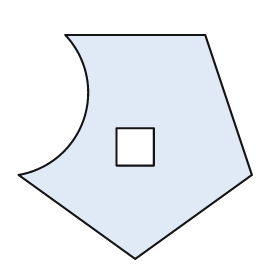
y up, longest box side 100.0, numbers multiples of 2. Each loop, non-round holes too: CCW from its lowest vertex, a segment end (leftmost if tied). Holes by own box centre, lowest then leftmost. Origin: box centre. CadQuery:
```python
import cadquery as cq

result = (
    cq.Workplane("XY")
    .moveTo(0.0, -48.0)
    .lineTo(50.0, -12.0)
    .lineTo(30.0, 48.0)
    .lineTo(-30.0, 48.0)
    .threePointArc((-22.0, 12.0), (-50.0, -12.0))
    .close()
    .moveTo(-8.0, -8.0)
    .lineTo(8.0, -8.0)
    .lineTo(8.0, 8.0)
    .lineTo(-8.0, 8.0)
    .close()
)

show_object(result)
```